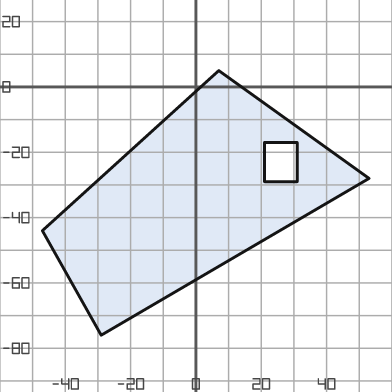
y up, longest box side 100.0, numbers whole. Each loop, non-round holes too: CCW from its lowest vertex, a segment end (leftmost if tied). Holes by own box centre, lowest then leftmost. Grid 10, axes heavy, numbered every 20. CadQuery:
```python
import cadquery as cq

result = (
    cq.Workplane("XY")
    .moveTo(-29.0, -76.0)
    .lineTo(53.0, -28.0)
    .lineTo(7.0, 5.0)
    .lineTo(-47.0, -44.0)
    .close()
    .moveTo(21.0, -29.0)
    .lineTo(31.0, -29.0)
    .lineTo(31.0, -17.0)
    .lineTo(21.0, -17.0)
    .close()
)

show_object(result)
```